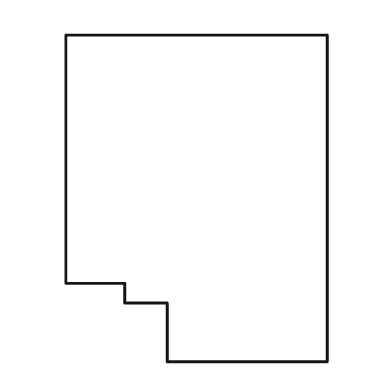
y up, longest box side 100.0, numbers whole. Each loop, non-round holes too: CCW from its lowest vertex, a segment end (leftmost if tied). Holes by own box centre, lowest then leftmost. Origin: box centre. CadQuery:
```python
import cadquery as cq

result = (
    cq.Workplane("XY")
    .moveTo(-9.0, -50.0)
    .lineTo(40.0, -50.0)
    .lineTo(40.0, 50.0)
    .lineTo(-40.0, 50.0)
    .lineTo(-40.0, -26.0)
    .lineTo(-22.0, -26.0)
    .lineTo(-22.0, -32.0)
    .lineTo(-9.0, -32.0)
    .close()
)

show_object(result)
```